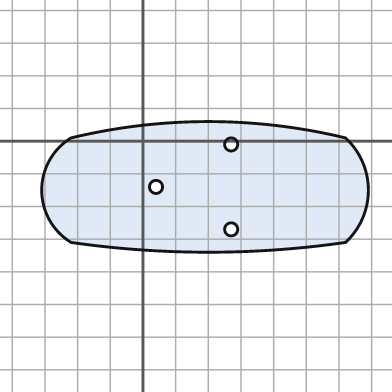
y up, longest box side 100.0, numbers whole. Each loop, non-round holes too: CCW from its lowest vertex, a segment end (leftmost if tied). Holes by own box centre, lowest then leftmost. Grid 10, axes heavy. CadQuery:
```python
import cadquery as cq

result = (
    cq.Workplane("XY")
    .moveTo(-22.0, -31.0)
    .threePointArc((20.0, -34.0), (62.0, -31.0))
    .threePointArc((69.0, -15.0), (62.0, 1.0))
    .threePointArc((20.0, 6.0), (-22.0, 1.0))
    .threePointArc((-31.0, -15.0), (-22.0, -31.0))
    .close()
    .moveTo(27.0, -27.0)
    .circle(2.0)
    .moveTo(4.0, -14.0)
    .circle(2.0)
    .moveTo(27.0, -1.0)
    .circle(2.0)
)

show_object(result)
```